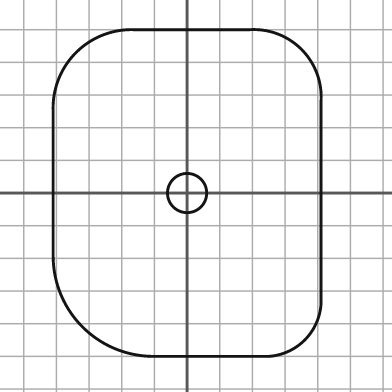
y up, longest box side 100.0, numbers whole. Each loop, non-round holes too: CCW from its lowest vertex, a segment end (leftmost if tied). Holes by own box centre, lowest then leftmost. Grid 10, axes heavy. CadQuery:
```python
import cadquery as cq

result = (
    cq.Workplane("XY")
    .moveTo(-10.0, -50.0)
    .lineTo(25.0, -50.0)
    .threePointArc((36.0, -45.0), (41.0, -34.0))
    .lineTo(41.0, 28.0)
    .threePointArc((35.0, 44.0), (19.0, 50.0))
    .lineTo(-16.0, 50.0)
    .threePointArc((-34.0, 43.0), (-41.0, 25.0))
    .lineTo(-41.0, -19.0)
    .threePointArc((-32.0, -41.0), (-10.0, -50.0))
    .close()
    .moveTo(0.0, 0.0)
    .circle(6.0)
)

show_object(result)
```